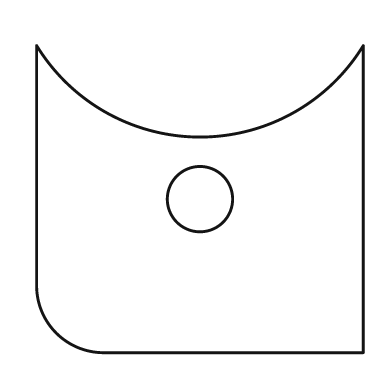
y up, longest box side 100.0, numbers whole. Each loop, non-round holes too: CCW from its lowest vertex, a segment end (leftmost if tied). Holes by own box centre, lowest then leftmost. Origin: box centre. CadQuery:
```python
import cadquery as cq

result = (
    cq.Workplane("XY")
    .moveTo(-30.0, -47.0)
    .lineTo(50.0, -47.0)
    .lineTo(50.0, 47.0)
    .threePointArc((0.0, 19.0), (-50.0, 47.0))
    .lineTo(-50.0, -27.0)
    .threePointArc((-44.0, -41.0), (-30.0, -47.0))
    .close()
    .moveTo(0.0, 0.0)
    .circle(10.0)
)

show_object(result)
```